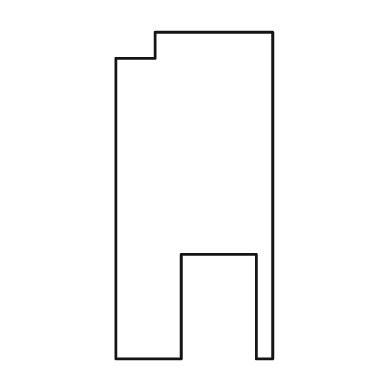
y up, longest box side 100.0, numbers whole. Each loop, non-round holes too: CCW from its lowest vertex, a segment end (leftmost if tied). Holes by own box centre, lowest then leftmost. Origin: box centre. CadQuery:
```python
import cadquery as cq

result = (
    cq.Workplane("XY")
    .moveTo(-24.0, -50.0)
    .lineTo(-4.0, -50.0)
    .lineTo(-4.0, -18.0)
    .lineTo(19.0, -18.0)
    .lineTo(19.0, -50.0)
    .lineTo(24.0, -50.0)
    .lineTo(24.0, 50.0)
    .lineTo(-12.0, 50.0)
    .lineTo(-12.0, 42.0)
    .lineTo(-24.0, 42.0)
    .close()
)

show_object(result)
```